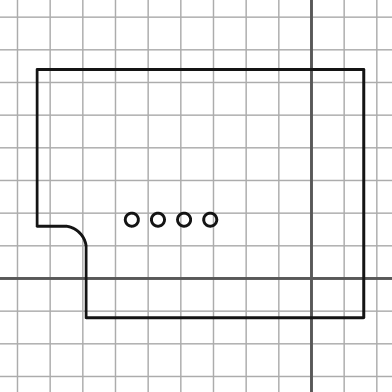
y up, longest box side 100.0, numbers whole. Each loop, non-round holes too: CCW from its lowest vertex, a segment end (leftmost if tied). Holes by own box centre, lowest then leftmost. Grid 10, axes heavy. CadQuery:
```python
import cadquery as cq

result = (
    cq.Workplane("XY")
    .moveTo(-69.0, -12.0)
    .lineTo(16.0, -12.0)
    .lineTo(16.0, 64.0)
    .lineTo(-84.0, 64.0)
    .lineTo(-84.0, 16.0)
    .lineTo(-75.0, 16.0)
    .threePointArc((-71.0, 14.0), (-69.0, 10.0))
    .close()
    .moveTo(-55.0, 18.0)
    .circle(2.0)
    .moveTo(-47.0, 18.0)
    .circle(2.0)
    .moveTo(-39.0, 18.0)
    .circle(2.0)
    .moveTo(-31.0, 18.0)
    .circle(2.0)
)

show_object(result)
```